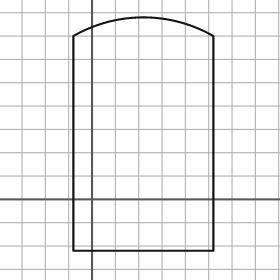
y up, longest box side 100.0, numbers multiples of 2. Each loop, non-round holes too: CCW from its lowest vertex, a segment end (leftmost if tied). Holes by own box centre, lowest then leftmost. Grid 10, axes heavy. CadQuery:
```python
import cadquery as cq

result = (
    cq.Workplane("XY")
    .moveTo(-8.0, -22.0)
    .lineTo(52.0, -22.0)
    .lineTo(52.0, 70.0)
    .threePointArc((22.0, 78.0), (-8.0, 70.0))
    .close()
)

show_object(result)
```